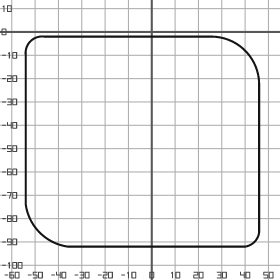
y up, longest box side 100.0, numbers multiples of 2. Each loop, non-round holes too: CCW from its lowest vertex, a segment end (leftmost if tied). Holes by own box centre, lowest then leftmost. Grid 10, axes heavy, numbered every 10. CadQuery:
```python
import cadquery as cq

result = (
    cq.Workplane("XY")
    .moveTo(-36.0, -92.0)
    .lineTo(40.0, -92.0)
    .threePointArc((44.0, -90.0), (46.0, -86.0))
    .lineTo(46.0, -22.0)
    .threePointArc((40.0, -8.0), (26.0, -2.0))
    .lineTo(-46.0, -2.0)
    .threePointArc((-52.0, -4.0), (-54.0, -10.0))
    .lineTo(-54.0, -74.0)
    .threePointArc((-48.0, -86.0), (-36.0, -92.0))
    .close()
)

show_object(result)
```